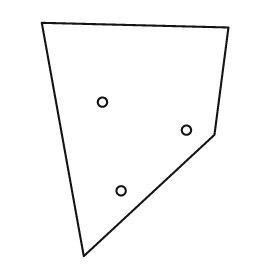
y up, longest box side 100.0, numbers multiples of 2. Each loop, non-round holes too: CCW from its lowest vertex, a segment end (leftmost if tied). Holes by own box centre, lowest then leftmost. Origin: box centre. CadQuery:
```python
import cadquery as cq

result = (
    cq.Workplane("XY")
    .moveTo(-22.0, -50.0)
    .lineTo(34.0, 2.0)
    .lineTo(40.0, 48.0)
    .lineTo(-40.0, 50.0)
    .close()
    .moveTo(-6.0, -22.0)
    .circle(2.0)
    .moveTo(22.0, 4.0)
    .circle(2.0)
    .moveTo(-14.0, 16.0)
    .circle(2.0)
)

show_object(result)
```